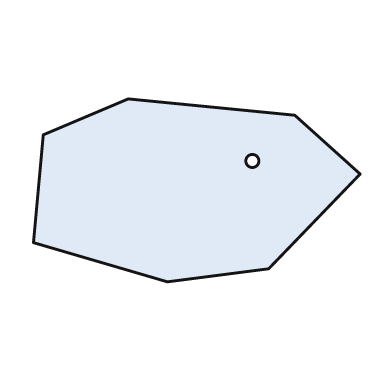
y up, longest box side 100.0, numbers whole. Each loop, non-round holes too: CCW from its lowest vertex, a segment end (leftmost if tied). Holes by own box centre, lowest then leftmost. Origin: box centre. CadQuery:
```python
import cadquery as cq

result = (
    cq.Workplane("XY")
    .moveTo(-9.0, -28.0)
    .lineTo(22.0, -24.0)
    .lineTo(50.0, 5.0)
    .lineTo(30.0, 23.0)
    .lineTo(-21.0, 28.0)
    .lineTo(-47.0, 17.0)
    .lineTo(-50.0, -16.0)
    .close()
    .moveTo(17.0, 9.0)
    .circle(2.0)
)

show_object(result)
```